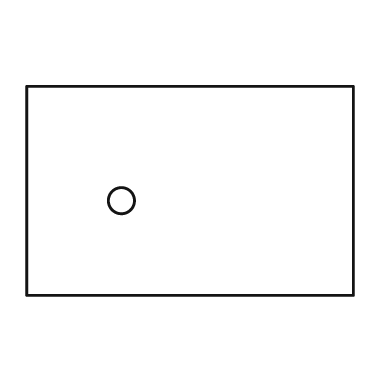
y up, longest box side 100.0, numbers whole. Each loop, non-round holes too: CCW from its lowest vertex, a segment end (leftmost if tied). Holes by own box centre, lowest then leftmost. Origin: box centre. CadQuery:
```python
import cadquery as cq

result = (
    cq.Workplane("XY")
    .moveTo(-50.0, -32.0)
    .lineTo(50.0, -32.0)
    .lineTo(50.0, 32.0)
    .lineTo(-50.0, 32.0)
    .close()
    .moveTo(-21.0, -3.0)
    .circle(4.0)
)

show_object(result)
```